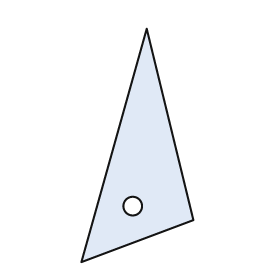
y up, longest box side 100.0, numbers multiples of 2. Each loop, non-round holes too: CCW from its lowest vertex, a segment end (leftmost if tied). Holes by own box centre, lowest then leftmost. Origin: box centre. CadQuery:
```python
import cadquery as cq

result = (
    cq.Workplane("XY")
    .moveTo(-24.0, -50.0)
    .lineTo(24.0, -32.0)
    .lineTo(4.0, 50.0)
    .close()
    .moveTo(-2.0, -26.0)
    .circle(4.0)
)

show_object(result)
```